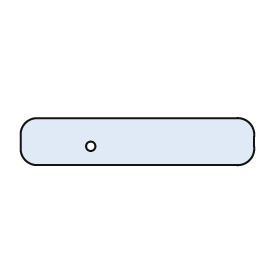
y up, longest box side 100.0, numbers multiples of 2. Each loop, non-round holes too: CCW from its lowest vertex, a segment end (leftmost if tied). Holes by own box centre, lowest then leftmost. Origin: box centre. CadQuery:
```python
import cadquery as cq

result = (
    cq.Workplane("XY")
    .moveTo(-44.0, -10.0)
    .lineTo(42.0, -10.0)
    .threePointArc((48.0, -8.0), (50.0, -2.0))
    .lineTo(50.0, 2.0)
    .threePointArc((48.0, 8.0), (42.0, 10.0))
    .lineTo(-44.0, 10.0)
    .threePointArc((-48.0, 8.0), (-50.0, 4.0))
    .lineTo(-50.0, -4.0)
    .threePointArc((-48.0, -8.0), (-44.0, -10.0))
    .close()
    .moveTo(-20.0, -2.0)
    .circle(2.0)
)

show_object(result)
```